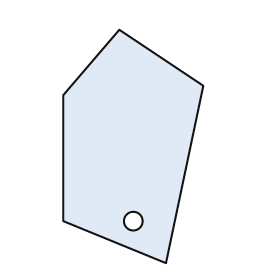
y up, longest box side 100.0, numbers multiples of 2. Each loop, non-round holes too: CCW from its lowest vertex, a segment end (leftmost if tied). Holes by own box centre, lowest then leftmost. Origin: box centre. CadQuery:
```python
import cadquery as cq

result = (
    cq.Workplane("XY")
    .moveTo(14.0, -50.0)
    .lineTo(30.0, 26.0)
    .lineTo(-6.0, 50.0)
    .lineTo(-30.0, 22.0)
    .lineTo(-30.0, -32.0)
    .close()
    .moveTo(0.0, -32.0)
    .circle(4.0)
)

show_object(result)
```